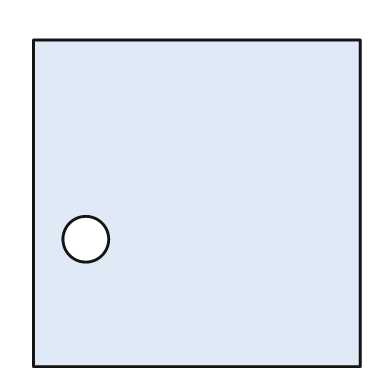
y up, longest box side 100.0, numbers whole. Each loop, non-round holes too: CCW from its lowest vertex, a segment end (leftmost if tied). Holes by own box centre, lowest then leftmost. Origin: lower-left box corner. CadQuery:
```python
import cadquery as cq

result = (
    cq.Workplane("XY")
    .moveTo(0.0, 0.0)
    .lineTo(100.0, 0.0)
    .lineTo(100.0, 100.0)
    .lineTo(0.0, 100.0)
    .close()
    .moveTo(16.0, 39.0)
    .circle(7.0)
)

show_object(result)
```